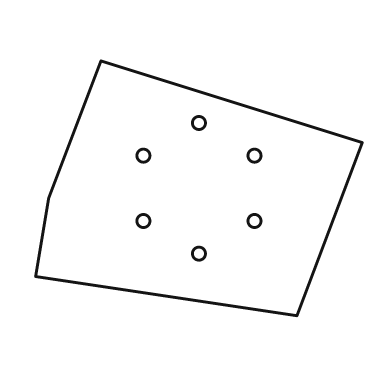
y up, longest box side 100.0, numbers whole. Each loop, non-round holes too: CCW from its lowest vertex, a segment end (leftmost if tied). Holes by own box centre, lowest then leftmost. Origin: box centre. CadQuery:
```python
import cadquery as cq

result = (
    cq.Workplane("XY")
    .moveTo(30.0, -39.0)
    .lineTo(50.0, 14.0)
    .lineTo(-30.0, 39.0)
    .lineTo(-46.0, -3.0)
    .lineTo(-50.0, -27.0)
    .close()
    .moveTo(0.0, -20.0)
    .circle(2.0)
    .moveTo(-17.0, -10.0)
    .circle(2.0)
    .moveTo(17.0, -10.0)
    .circle(2.0)
    .moveTo(-17.0, 10.0)
    .circle(2.0)
    .moveTo(17.0, 10.0)
    .circle(2.0)
    .moveTo(0.0, 20.0)
    .circle(2.0)
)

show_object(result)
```